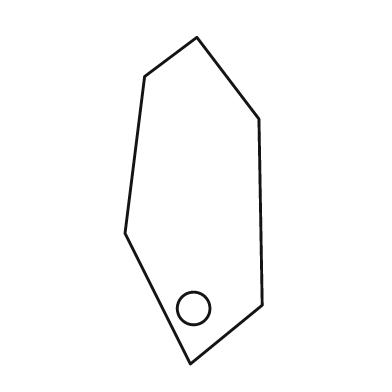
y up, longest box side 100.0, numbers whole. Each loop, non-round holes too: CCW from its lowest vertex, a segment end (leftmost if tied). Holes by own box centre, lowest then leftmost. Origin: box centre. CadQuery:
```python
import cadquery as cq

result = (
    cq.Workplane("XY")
    .moveTo(-1.0, -50.0)
    .lineTo(21.0, -32.0)
    .lineTo(20.0, 25.0)
    .lineTo(1.0, 50.0)
    .lineTo(-15.0, 38.0)
    .lineTo(-21.0, -10.0)
    .close()
    .moveTo(0.0, -33.0)
    .circle(5.0)
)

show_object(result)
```